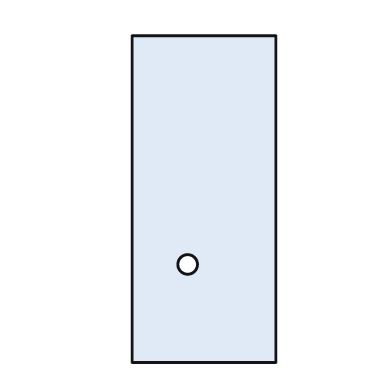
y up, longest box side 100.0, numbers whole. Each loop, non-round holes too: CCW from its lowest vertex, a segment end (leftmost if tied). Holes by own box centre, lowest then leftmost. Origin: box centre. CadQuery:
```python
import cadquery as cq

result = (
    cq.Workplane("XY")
    .moveTo(-22.0, -50.0)
    .lineTo(22.0, -50.0)
    .lineTo(22.0, 50.0)
    .lineTo(-22.0, 50.0)
    .close()
    .moveTo(-5.0, -20.0)
    .circle(3.0)
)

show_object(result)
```